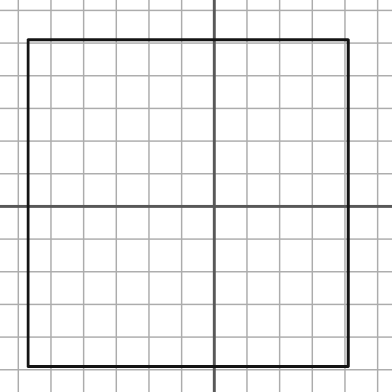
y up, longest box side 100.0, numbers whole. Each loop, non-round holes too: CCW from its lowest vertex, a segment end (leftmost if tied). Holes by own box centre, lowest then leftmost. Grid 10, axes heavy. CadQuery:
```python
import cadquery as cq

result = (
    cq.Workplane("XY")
    .moveTo(-57.0, -49.0)
    .lineTo(41.0, -49.0)
    .lineTo(41.0, 51.0)
    .lineTo(-57.0, 51.0)
    .close()
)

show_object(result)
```